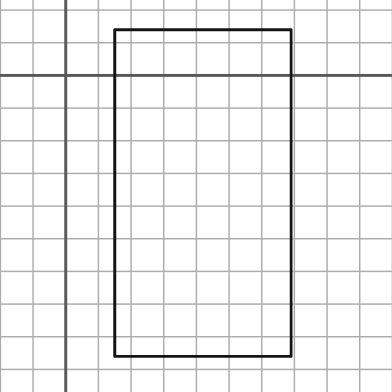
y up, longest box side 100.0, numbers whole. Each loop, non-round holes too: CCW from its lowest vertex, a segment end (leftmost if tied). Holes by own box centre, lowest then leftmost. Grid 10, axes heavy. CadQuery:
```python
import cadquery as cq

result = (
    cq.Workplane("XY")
    .moveTo(15.0, -86.0)
    .lineTo(69.0, -86.0)
    .lineTo(69.0, 14.0)
    .lineTo(15.0, 14.0)
    .close()
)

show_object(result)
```